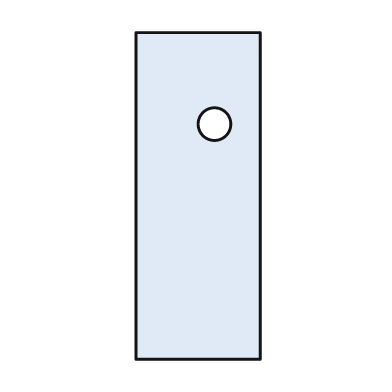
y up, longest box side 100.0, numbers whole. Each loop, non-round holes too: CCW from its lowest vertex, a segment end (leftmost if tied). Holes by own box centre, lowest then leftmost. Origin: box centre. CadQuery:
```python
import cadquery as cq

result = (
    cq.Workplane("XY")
    .moveTo(-19.0, -50.0)
    .lineTo(19.0, -50.0)
    .lineTo(19.0, 50.0)
    .lineTo(-19.0, 50.0)
    .close()
    .moveTo(5.0, 22.0)
    .circle(5.0)
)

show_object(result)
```